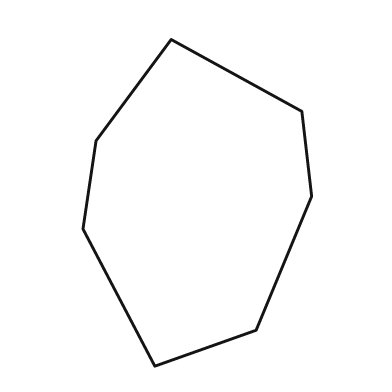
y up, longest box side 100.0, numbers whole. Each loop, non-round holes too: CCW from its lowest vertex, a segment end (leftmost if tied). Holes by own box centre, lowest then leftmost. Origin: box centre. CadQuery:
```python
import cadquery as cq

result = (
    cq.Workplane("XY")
    .moveTo(-13.0, -50.0)
    .lineTo(18.0, -39.0)
    .lineTo(35.0, 2.0)
    .lineTo(32.0, 28.0)
    .lineTo(-8.0, 50.0)
    .lineTo(-31.0, 19.0)
    .lineTo(-35.0, -8.0)
    .close()
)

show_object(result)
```